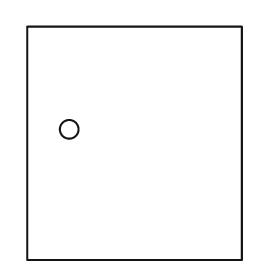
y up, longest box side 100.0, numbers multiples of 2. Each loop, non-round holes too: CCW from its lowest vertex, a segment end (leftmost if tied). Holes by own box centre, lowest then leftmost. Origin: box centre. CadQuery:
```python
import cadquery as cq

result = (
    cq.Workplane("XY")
    .moveTo(-46.0, -50.0)
    .lineTo(46.0, -50.0)
    .lineTo(46.0, 50.0)
    .lineTo(-46.0, 50.0)
    .close()
    .moveTo(-28.0, 6.0)
    .circle(4.0)
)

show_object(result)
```